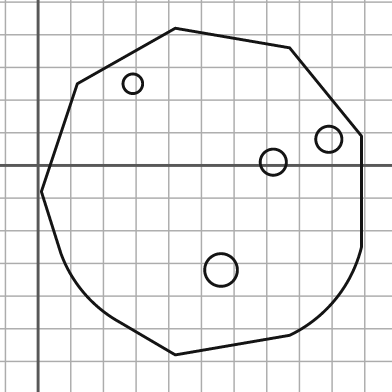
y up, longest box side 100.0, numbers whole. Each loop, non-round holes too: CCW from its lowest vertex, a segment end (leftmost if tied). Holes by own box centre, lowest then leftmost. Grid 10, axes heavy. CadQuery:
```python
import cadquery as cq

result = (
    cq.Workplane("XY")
    .moveTo(42.0, -58.0)
    .lineTo(77.0, -52.0)
    .threePointArc((91.0, -41.0), (99.0, -25.0))
    .lineTo(99.0, 9.0)
    .lineTo(77.0, 36.0)
    .lineTo(42.0, 42.0)
    .lineTo(12.0, 25.0)
    .lineTo(1.0, -8.0)
    .lineTo(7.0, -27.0)
    .threePointArc((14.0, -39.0), (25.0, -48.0))
    .close()
    .moveTo(56.0, -32.0)
    .circle(5.0)
    .moveTo(72.0, 1.0)
    .circle(4.0)
    .moveTo(89.0, 8.0)
    .circle(4.0)
    .moveTo(29.0, 25.0)
    .circle(3.0)
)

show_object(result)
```